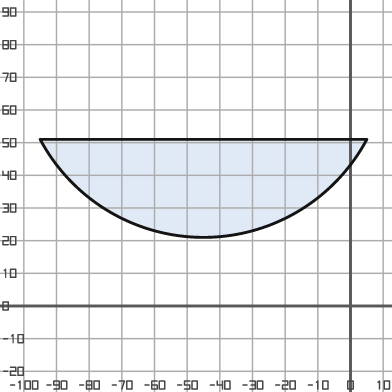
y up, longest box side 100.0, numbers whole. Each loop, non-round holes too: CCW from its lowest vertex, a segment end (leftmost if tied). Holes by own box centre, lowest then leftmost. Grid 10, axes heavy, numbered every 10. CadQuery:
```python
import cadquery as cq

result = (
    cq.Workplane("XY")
    .moveTo(-95.0, 51.0)
    .threePointArc((-45.0, 21.0), (5.0, 51.0))
    .close()
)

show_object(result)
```